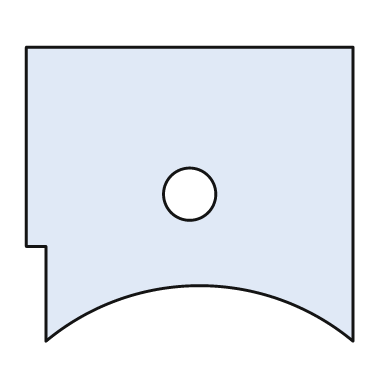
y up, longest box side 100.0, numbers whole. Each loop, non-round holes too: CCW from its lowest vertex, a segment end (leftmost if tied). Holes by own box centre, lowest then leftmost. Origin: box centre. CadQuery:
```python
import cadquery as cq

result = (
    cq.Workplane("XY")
    .moveTo(-44.0, -45.0)
    .threePointArc((3.0, -28.0), (50.0, -45.0))
    .lineTo(50.0, 45.0)
    .lineTo(-50.0, 45.0)
    .lineTo(-50.0, -16.0)
    .lineTo(-44.0, -16.0)
    .close()
    .moveTo(0.0, 0.0)
    .circle(8.0)
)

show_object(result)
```